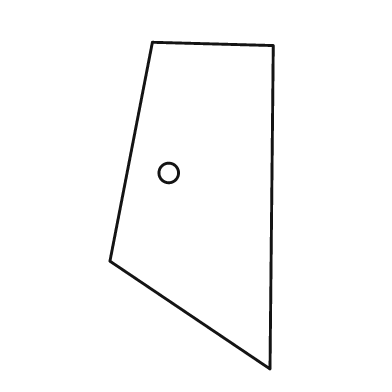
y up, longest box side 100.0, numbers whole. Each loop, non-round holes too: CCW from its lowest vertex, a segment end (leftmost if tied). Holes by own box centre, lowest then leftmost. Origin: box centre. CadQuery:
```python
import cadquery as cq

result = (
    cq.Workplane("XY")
    .moveTo(24.0, -50.0)
    .lineTo(25.0, 49.0)
    .lineTo(-12.0, 50.0)
    .lineTo(-25.0, -17.0)
    .close()
    .moveTo(-7.0, 10.0)
    .circle(3.0)
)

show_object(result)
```